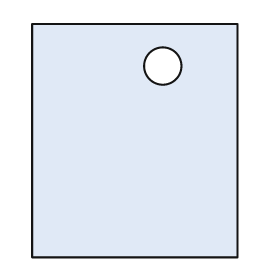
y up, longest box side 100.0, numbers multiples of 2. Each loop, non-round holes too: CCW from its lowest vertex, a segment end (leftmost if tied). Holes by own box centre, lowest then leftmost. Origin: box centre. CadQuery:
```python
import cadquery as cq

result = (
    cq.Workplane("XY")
    .moveTo(-44.0, -50.0)
    .lineTo(44.0, -50.0)
    .lineTo(44.0, 50.0)
    .lineTo(-44.0, 50.0)
    .close()
    .moveTo(12.0, 32.0)
    .circle(8.0)
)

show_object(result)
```